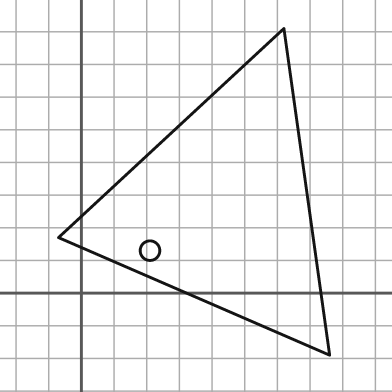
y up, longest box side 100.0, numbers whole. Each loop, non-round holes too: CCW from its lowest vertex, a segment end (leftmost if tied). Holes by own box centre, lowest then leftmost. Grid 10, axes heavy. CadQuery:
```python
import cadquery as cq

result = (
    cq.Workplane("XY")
    .moveTo(76.0, -19.0)
    .lineTo(62.0, 81.0)
    .lineTo(-7.0, 17.0)
    .close()
    .moveTo(21.0, 13.0)
    .circle(3.0)
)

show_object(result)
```